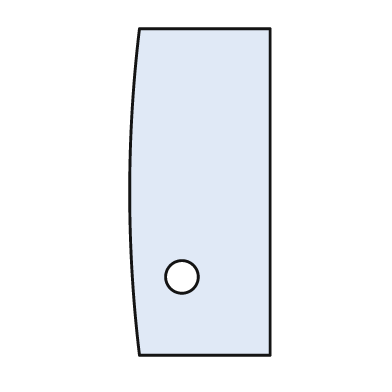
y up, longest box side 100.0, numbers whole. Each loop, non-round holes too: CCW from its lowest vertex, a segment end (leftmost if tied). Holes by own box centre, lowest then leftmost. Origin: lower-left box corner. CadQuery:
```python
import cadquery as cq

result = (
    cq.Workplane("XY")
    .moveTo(3.0, 0.0)
    .lineTo(43.0, 0.0)
    .lineTo(43.0, 100.0)
    .lineTo(3.0, 100.0)
    .threePointArc((0.0, 50.0), (3.0, 0.0))
    .close()
    .moveTo(16.0, 24.0)
    .circle(5.0)
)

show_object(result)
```